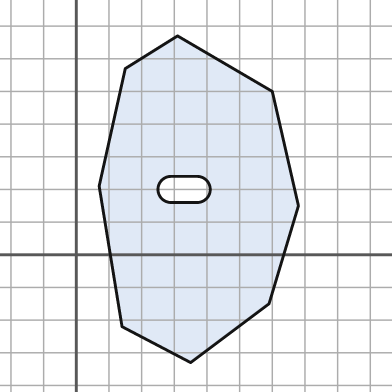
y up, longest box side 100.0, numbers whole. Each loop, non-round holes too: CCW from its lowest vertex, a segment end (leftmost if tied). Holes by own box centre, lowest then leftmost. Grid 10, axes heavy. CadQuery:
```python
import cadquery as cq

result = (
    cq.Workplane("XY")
    .moveTo(35.0, -33.0)
    .lineTo(59.0, -15.0)
    .lineTo(68.0, 15.0)
    .lineTo(60.0, 50.0)
    .lineTo(31.0, 67.0)
    .lineTo(15.0, 57.0)
    .lineTo(7.0, 21.0)
    .lineTo(14.0, -22.0)
    .close()
    .moveTo(29.0, 16.0)
    .lineTo(37.0, 16.0)
    .threePointArc((41.0, 20.0), (37.0, 24.0))
    .lineTo(29.0, 24.0)
    .threePointArc((25.0, 20.0), (29.0, 16.0))
    .close()
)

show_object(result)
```